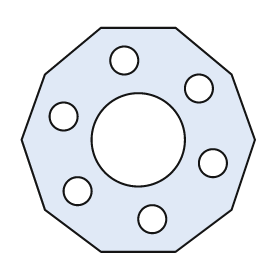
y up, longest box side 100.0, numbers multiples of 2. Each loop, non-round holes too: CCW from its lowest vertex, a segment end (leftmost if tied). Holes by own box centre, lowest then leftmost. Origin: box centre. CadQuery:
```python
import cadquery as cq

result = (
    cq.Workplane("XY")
    .moveTo(-16.0, -48.0)
    .lineTo(16.0, -48.0)
    .lineTo(40.0, -30.0)
    .lineTo(50.0, 0.0)
    .lineTo(40.0, 28.0)
    .lineTo(16.0, 48.0)
    .lineTo(-16.0, 48.0)
    .lineTo(-40.0, 28.0)
    .lineTo(-50.0, 0.0)
    .lineTo(-40.0, -30.0)
    .close()
    .moveTo(6.0, -34.0)
    .circle(6.0)
    .moveTo(-26.0, -22.0)
    .circle(6.0)
    .moveTo(32.0, -10.0)
    .circle(6.0)
    .moveTo(0.0, 0.0)
    .circle(20.0)
    .moveTo(-32.0, 10.0)
    .circle(6.0)
    .moveTo(26.0, 22.0)
    .circle(6.0)
    .moveTo(-6.0, 34.0)
    .circle(6.0)
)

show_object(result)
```